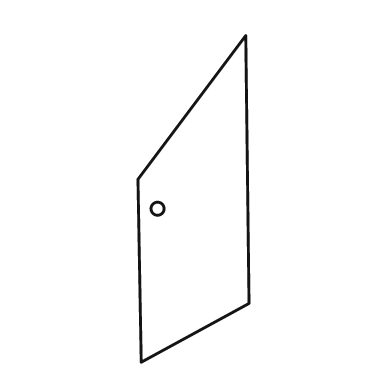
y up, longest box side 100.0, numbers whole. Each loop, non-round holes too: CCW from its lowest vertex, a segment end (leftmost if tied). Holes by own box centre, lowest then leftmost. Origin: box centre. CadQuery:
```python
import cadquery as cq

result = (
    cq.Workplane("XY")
    .moveTo(-16.0, -50.0)
    .lineTo(17.0, -32.0)
    .lineTo(16.0, 50.0)
    .lineTo(-17.0, 6.0)
    .close()
    .moveTo(-11.0, -3.0)
    .circle(2.0)
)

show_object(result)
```